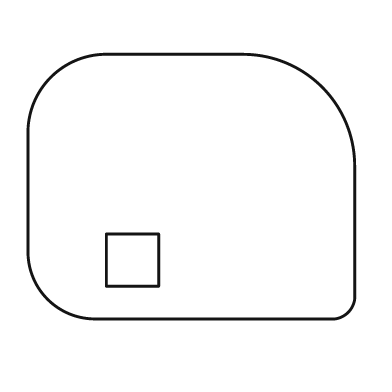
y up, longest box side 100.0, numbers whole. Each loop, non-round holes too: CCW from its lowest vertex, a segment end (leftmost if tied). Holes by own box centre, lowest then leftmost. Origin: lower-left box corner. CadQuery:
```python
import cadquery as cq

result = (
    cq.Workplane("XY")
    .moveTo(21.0, 0.0)
    .lineTo(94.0, 0.0)
    .threePointArc((98.0, 2.0), (100.0, 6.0))
    .lineTo(100.0, 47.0)
    .threePointArc((90.0, 71.0), (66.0, 81.0))
    .lineTo(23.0, 81.0)
    .threePointArc((7.0, 74.0), (0.0, 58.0))
    .lineTo(0.0, 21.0)
    .threePointArc((6.0, 6.0), (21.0, 0.0))
    .close()
    .moveTo(24.0, 10.0)
    .lineTo(40.0, 10.0)
    .lineTo(40.0, 26.0)
    .lineTo(24.0, 26.0)
    .close()
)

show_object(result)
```